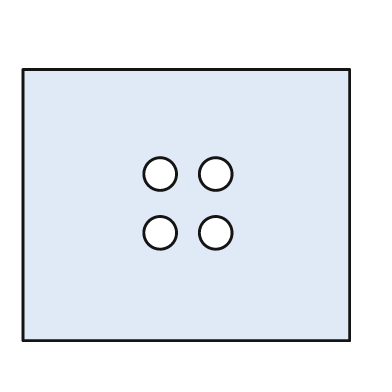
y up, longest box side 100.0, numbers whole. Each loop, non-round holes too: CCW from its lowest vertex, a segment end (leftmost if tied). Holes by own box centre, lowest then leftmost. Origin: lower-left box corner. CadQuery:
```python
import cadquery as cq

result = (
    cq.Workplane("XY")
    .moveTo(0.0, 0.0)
    .lineTo(100.0, 0.0)
    .lineTo(100.0, 83.0)
    .lineTo(0.0, 83.0)
    .close()
    .moveTo(42.0, 33.0)
    .circle(5.0)
    .moveTo(59.0, 33.0)
    .circle(5.0)
    .moveTo(42.0, 51.0)
    .circle(5.0)
    .moveTo(59.0, 51.0)
    .circle(5.0)
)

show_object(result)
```